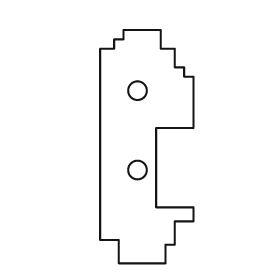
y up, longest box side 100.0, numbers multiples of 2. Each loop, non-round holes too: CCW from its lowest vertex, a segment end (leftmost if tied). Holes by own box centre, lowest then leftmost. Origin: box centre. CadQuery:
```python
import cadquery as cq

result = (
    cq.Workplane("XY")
    .moveTo(-12.0, -50.0)
    .lineTo(8.0, -50.0)
    .lineTo(8.0, -42.0)
    .lineTo(12.0, -42.0)
    .lineTo(12.0, -32.0)
    .lineTo(20.0, -32.0)
    .lineTo(20.0, -26.0)
    .lineTo(4.0, -26.0)
    .lineTo(4.0, 8.0)
    .lineTo(20.0, 8.0)
    .lineTo(20.0, 30.0)
    .lineTo(16.0, 30.0)
    .lineTo(16.0, 34.0)
    .lineTo(12.0, 34.0)
    .lineTo(12.0, 42.0)
    .lineTo(6.0, 42.0)
    .lineTo(6.0, 50.0)
    .lineTo(-10.0, 50.0)
    .lineTo(-10.0, 46.0)
    .lineTo(-14.0, 46.0)
    .lineTo(-14.0, 42.0)
    .lineTo(-20.0, 42.0)
    .lineTo(-20.0, -40.0)
    .lineTo(-12.0, -40.0)
    .close()
    .moveTo(-4.0, -10.0)
    .circle(4.0)
    .moveTo(-4.0, 24.0)
    .circle(4.0)
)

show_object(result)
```